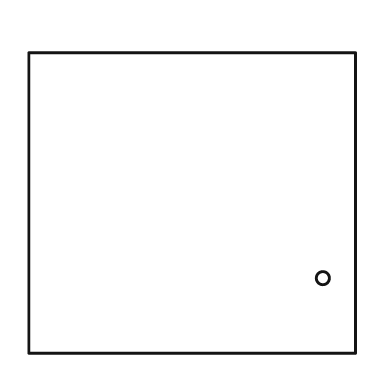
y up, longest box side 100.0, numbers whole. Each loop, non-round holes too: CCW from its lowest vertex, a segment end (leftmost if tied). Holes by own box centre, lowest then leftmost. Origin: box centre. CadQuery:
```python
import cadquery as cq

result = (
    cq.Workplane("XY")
    .moveTo(-50.0, -46.0)
    .lineTo(50.0, -46.0)
    .lineTo(50.0, 46.0)
    .lineTo(-50.0, 46.0)
    .close()
    .moveTo(40.0, -23.0)
    .circle(2.0)
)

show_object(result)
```